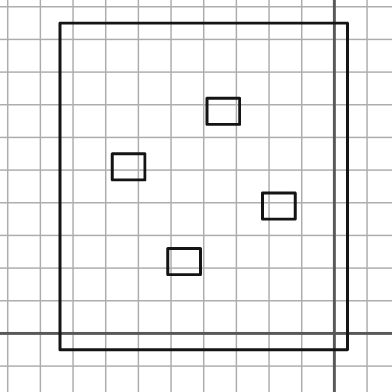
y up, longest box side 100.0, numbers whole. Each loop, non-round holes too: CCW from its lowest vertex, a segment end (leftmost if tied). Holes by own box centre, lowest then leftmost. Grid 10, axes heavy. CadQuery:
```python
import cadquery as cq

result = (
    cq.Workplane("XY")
    .moveTo(-84.0, -5.0)
    .lineTo(4.0, -5.0)
    .lineTo(4.0, 95.0)
    .lineTo(-84.0, 95.0)
    .close()
    .moveTo(-51.0, 18.0)
    .lineTo(-41.0, 18.0)
    .lineTo(-41.0, 26.0)
    .lineTo(-51.0, 26.0)
    .close()
    .moveTo(-22.0, 35.0)
    .lineTo(-12.0, 35.0)
    .lineTo(-12.0, 43.0)
    .lineTo(-22.0, 43.0)
    .close()
    .moveTo(-68.0, 47.0)
    .lineTo(-58.0, 47.0)
    .lineTo(-58.0, 55.0)
    .lineTo(-68.0, 55.0)
    .close()
    .moveTo(-39.0, 64.0)
    .lineTo(-29.0, 64.0)
    .lineTo(-29.0, 72.0)
    .lineTo(-39.0, 72.0)
    .close()
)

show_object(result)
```